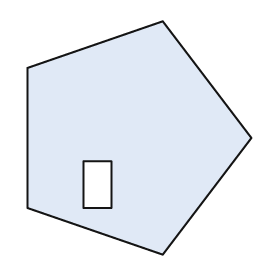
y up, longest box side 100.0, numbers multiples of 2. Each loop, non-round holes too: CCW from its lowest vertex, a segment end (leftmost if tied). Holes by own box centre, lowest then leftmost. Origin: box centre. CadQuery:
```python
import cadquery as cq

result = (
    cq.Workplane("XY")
    .moveTo(10.0, -50.0)
    .lineTo(48.0, 0.0)
    .lineTo(10.0, 50.0)
    .lineTo(-48.0, 30.0)
    .lineTo(-48.0, -30.0)
    .close()
    .moveTo(-24.0, -30.0)
    .lineTo(-12.0, -30.0)
    .lineTo(-12.0, -10.0)
    .lineTo(-24.0, -10.0)
    .close()
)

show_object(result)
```